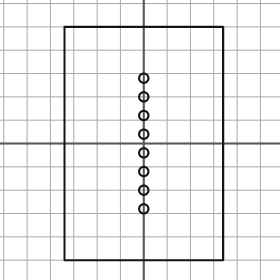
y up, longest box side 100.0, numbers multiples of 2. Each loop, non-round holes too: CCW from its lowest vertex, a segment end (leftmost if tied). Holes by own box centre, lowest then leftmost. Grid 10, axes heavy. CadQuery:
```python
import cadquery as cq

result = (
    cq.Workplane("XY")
    .moveTo(-34.0, -50.0)
    .lineTo(34.0, -50.0)
    .lineTo(34.0, 50.0)
    .lineTo(-34.0, 50.0)
    .close()
    .moveTo(0.0, -28.0)
    .circle(2.0)
    .moveTo(0.0, -20.0)
    .circle(2.0)
    .moveTo(0.0, -12.0)
    .circle(2.0)
    .moveTo(0.0, -4.0)
    .circle(2.0)
    .moveTo(0.0, 4.0)
    .circle(2.0)
    .moveTo(0.0, 12.0)
    .circle(2.0)
    .moveTo(0.0, 20.0)
    .circle(2.0)
    .moveTo(0.0, 28.0)
    .circle(2.0)
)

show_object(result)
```